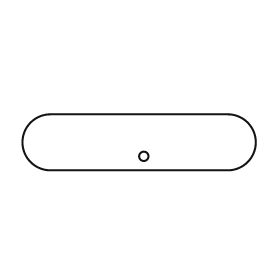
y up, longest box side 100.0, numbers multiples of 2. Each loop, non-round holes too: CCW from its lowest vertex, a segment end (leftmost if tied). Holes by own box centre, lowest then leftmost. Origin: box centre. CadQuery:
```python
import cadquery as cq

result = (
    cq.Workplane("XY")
    .moveTo(-38.0, -12.0)
    .lineTo(38.0, -12.0)
    .threePointArc((50.0, 0.0), (38.0, 12.0))
    .lineTo(-38.0, 12.0)
    .threePointArc((-50.0, 0.0), (-38.0, -12.0))
    .close()
    .moveTo(2.0, -6.0)
    .circle(2.0)
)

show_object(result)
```